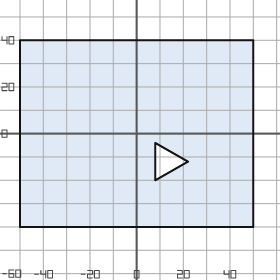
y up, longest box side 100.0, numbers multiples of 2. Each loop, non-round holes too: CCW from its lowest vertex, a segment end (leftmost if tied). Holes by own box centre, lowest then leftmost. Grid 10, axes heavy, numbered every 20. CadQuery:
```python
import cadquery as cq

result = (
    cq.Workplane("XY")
    .moveTo(-50.0, -40.0)
    .lineTo(50.0, -40.0)
    .lineTo(50.0, 40.0)
    .lineTo(-50.0, 40.0)
    .close()
    .moveTo(8.0, -20.0)
    .lineTo(22.0, -12.0)
    .lineTo(8.0, -4.0)
    .close()
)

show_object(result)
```